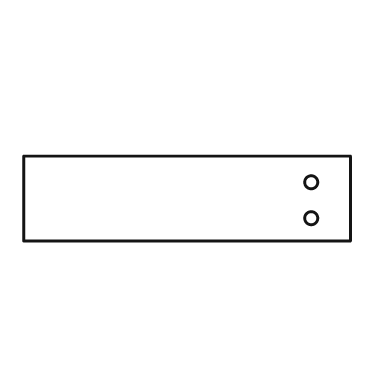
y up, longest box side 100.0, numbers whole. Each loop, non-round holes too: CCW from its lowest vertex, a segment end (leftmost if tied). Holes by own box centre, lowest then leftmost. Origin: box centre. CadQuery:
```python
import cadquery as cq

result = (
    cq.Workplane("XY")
    .moveTo(-50.0, -13.0)
    .lineTo(50.0, -13.0)
    .lineTo(50.0, 13.0)
    .lineTo(-50.0, 13.0)
    .close()
    .moveTo(38.0, -6.0)
    .circle(2.0)
    .moveTo(38.0, 5.0)
    .circle(2.0)
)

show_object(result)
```